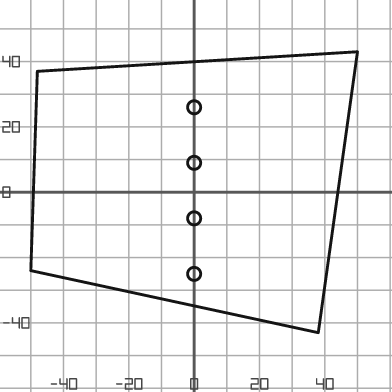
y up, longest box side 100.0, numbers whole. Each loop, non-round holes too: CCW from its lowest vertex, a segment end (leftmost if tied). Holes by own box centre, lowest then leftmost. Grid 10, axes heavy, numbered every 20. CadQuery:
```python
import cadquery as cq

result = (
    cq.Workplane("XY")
    .moveTo(38.0, -43.0)
    .lineTo(50.0, 43.0)
    .lineTo(-48.0, 37.0)
    .lineTo(-50.0, -24.0)
    .close()
    .moveTo(0.0, -25.0)
    .circle(2.0)
    .moveTo(0.0, -8.0)
    .circle(2.0)
    .moveTo(0.0, 9.0)
    .circle(2.0)
    .moveTo(0.0, 26.0)
    .circle(2.0)
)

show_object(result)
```